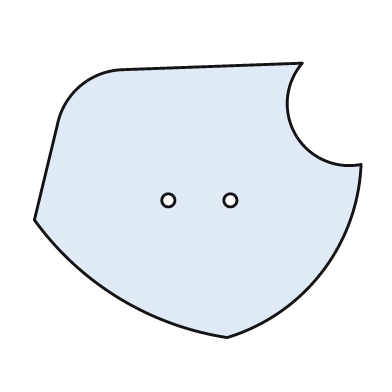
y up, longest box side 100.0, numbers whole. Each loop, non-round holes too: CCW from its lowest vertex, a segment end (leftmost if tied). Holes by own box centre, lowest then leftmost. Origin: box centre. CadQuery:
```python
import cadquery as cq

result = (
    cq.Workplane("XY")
    .moveTo(9.0, -42.0)
    .threePointArc((38.0, -22.0), (50.0, 11.0))
    .threePointArc((30.0, 20.0), (32.0, 42.0))
    .lineTo(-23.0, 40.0)
    .threePointArc((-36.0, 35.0), (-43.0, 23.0))
    .lineTo(-50.0, -6.0)
    .threePointArc((-24.0, -30.0), (9.0, -42.0))
    .close()
    .moveTo(-9.0, 0.0)
    .circle(2.0)
    .moveTo(10.0, 0.0)
    .circle(2.0)
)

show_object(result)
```